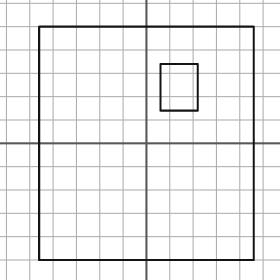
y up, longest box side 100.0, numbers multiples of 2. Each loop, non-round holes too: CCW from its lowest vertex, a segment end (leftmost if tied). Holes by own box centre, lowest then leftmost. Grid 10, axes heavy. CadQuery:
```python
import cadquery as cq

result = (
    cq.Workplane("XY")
    .moveTo(-46.0, -50.0)
    .lineTo(46.0, -50.0)
    .lineTo(46.0, 50.0)
    .lineTo(-46.0, 50.0)
    .close()
    .moveTo(6.0, 14.0)
    .lineTo(22.0, 14.0)
    .lineTo(22.0, 34.0)
    .lineTo(6.0, 34.0)
    .close()
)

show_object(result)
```